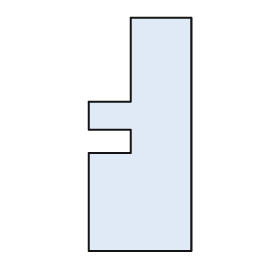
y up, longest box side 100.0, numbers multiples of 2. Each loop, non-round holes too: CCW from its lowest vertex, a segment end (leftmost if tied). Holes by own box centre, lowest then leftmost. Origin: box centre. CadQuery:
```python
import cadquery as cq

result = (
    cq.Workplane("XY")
    .moveTo(-22.0, -50.0)
    .lineTo(22.0, -50.0)
    .lineTo(22.0, 50.0)
    .lineTo(-4.0, 50.0)
    .lineTo(-4.0, 14.0)
    .lineTo(-22.0, 14.0)
    .lineTo(-22.0, 2.0)
    .lineTo(-4.0, 2.0)
    .lineTo(-4.0, -8.0)
    .lineTo(-22.0, -8.0)
    .close()
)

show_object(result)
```